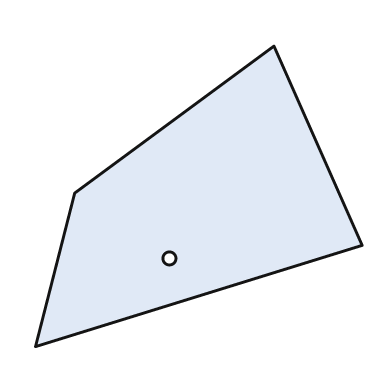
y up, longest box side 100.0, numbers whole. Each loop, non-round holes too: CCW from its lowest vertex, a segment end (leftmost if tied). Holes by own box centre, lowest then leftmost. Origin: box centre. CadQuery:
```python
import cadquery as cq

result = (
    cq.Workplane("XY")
    .moveTo(-50.0, -46.0)
    .lineTo(50.0, -15.0)
    .lineTo(23.0, 46.0)
    .lineTo(-38.0, 1.0)
    .close()
    .moveTo(-9.0, -19.0)
    .circle(2.0)
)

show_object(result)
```